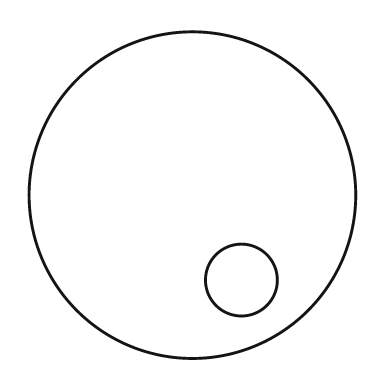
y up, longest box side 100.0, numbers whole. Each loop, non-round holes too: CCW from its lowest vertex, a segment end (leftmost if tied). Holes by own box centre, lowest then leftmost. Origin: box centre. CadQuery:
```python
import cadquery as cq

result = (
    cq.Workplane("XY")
    .moveTo(0.0, 0.0)
    .circle(50.0)
    .moveTo(15.0, -26.0)
    .circle(11.0)
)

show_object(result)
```